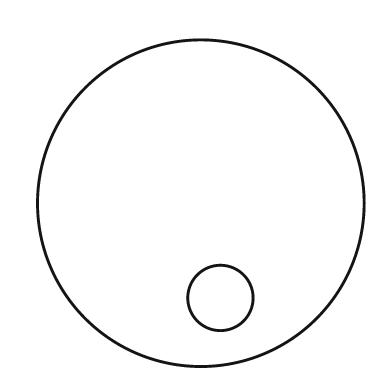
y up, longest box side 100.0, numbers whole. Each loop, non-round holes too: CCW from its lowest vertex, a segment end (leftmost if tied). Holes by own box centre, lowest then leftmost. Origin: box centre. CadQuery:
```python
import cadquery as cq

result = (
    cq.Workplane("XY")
    .moveTo(0.0, 0.0)
    .circle(50.0)
    .moveTo(6.0, -29.0)
    .circle(10.0)
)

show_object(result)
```